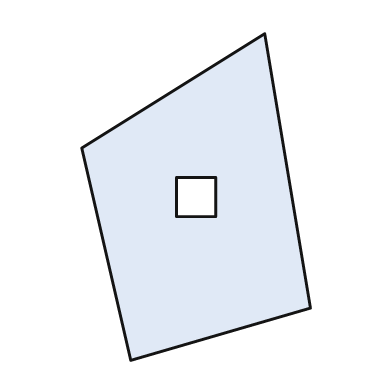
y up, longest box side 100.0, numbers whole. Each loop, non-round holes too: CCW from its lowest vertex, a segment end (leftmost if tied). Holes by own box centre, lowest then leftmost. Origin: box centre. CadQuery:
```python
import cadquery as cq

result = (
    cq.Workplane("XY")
    .moveTo(-20.0, -50.0)
    .lineTo(35.0, -34.0)
    .lineTo(21.0, 50.0)
    .lineTo(-35.0, 15.0)
    .close()
    .moveTo(-6.0, -6.0)
    .lineTo(6.0, -6.0)
    .lineTo(6.0, 6.0)
    .lineTo(-6.0, 6.0)
    .close()
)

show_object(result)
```